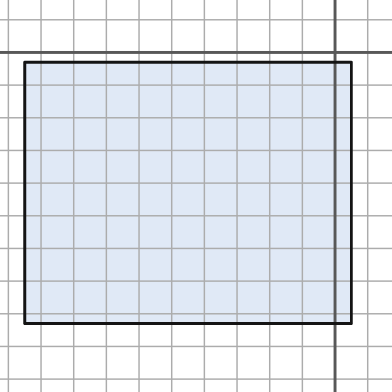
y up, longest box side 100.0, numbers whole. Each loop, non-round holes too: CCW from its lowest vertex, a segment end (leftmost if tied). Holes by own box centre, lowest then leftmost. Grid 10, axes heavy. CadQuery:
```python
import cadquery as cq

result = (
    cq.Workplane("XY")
    .moveTo(-95.0, -83.0)
    .lineTo(5.0, -83.0)
    .lineTo(5.0, -3.0)
    .lineTo(-95.0, -3.0)
    .close()
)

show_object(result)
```